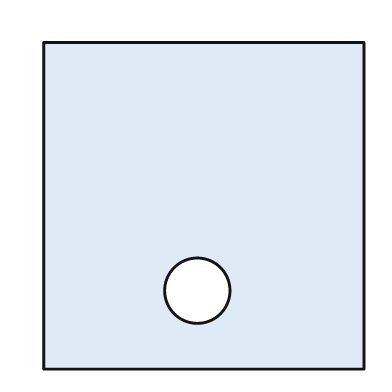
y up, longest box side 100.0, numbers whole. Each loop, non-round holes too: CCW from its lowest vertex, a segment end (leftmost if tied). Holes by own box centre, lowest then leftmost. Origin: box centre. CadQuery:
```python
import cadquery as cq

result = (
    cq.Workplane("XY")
    .moveTo(-49.0, -50.0)
    .lineTo(49.0, -50.0)
    .lineTo(49.0, 50.0)
    .lineTo(-49.0, 50.0)
    .close()
    .moveTo(-2.0, -26.0)
    .circle(10.0)
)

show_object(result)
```